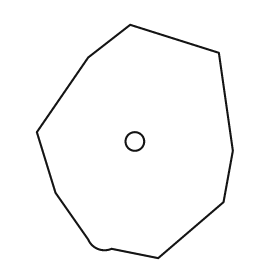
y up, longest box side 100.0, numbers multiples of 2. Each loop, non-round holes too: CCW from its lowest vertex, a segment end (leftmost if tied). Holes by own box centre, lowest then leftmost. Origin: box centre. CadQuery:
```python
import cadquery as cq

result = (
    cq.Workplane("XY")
    .moveTo(10.0, -50.0)
    .lineTo(38.0, -26.0)
    .lineTo(42.0, -4.0)
    .lineTo(36.0, 38.0)
    .lineTo(-2.0, 50.0)
    .lineTo(-20.0, 36.0)
    .lineTo(-42.0, 4.0)
    .lineTo(-34.0, -22.0)
    .lineTo(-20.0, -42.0)
    .threePointArc((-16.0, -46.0), (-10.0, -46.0))
    .close()
    .moveTo(0.0, 0.0)
    .circle(4.0)
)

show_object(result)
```